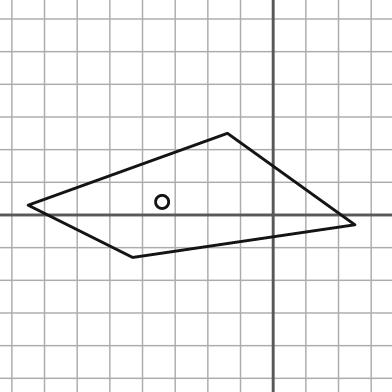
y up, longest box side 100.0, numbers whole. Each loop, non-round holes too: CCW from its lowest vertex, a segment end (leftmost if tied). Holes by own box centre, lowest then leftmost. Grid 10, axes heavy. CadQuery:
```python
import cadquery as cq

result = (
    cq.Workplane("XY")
    .moveTo(-43.0, -13.0)
    .lineTo(25.0, -3.0)
    .lineTo(-14.0, 25.0)
    .lineTo(-75.0, 3.0)
    .close()
    .moveTo(-34.0, 4.0)
    .circle(2.0)
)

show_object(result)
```